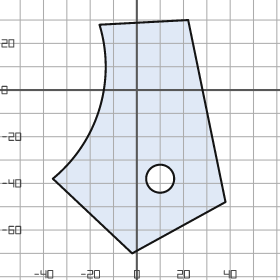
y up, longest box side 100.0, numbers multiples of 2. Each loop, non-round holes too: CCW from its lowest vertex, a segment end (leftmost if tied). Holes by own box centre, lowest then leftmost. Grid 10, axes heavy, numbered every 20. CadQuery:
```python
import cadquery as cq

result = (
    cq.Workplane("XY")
    .moveTo(-2.0, -70.0)
    .lineTo(38.0, -48.0)
    .lineTo(22.0, 30.0)
    .lineTo(-16.0, 28.0)
    .threePointArc((-16.0, -8.0), (-36.0, -38.0))
    .close()
    .moveTo(10.0, -38.0)
    .circle(6.0)
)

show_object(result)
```